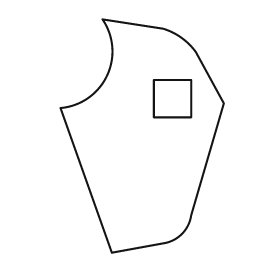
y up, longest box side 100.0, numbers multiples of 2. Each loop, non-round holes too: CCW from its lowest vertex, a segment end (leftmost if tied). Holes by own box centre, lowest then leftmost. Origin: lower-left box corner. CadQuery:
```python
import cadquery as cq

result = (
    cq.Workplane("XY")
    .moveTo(22.0, 0.0)
    .lineTo(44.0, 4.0)
    .threePointArc((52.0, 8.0), (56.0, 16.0))
    .lineTo(70.0, 64.0)
    .lineTo(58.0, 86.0)
    .threePointArc((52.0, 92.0), (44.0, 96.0))
    .lineTo(18.0, 100.0)
    .threePointArc((20.0, 76.0), (0.0, 62.0))
    .close()
    .moveTo(40.0, 58.0)
    .lineTo(56.0, 58.0)
    .lineTo(56.0, 74.0)
    .lineTo(40.0, 74.0)
    .close()
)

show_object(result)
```